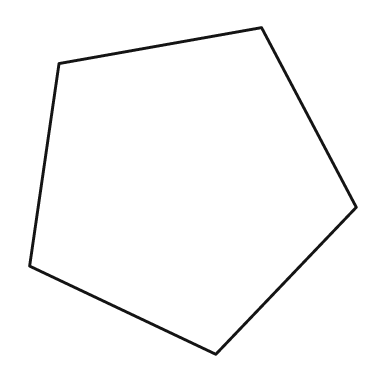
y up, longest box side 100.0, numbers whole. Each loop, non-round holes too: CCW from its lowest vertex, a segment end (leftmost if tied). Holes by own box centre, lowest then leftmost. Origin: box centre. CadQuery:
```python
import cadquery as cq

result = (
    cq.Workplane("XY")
    .moveTo(7.0, -50.0)
    .lineTo(50.0, -5.0)
    .lineTo(21.0, 50.0)
    .lineTo(-41.0, 39.0)
    .lineTo(-50.0, -23.0)
    .close()
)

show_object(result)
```